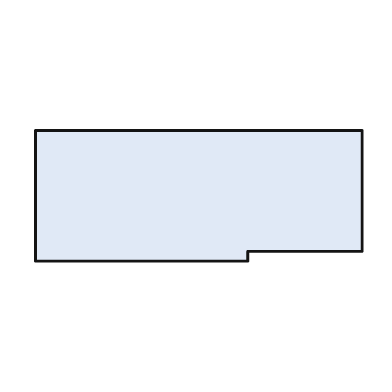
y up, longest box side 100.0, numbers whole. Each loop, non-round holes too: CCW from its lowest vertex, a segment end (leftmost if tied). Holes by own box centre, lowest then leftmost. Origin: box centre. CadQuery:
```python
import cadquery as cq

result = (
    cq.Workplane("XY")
    .moveTo(-50.0, -20.0)
    .lineTo(15.0, -20.0)
    .lineTo(15.0, -17.0)
    .lineTo(50.0, -17.0)
    .lineTo(50.0, 20.0)
    .lineTo(-50.0, 20.0)
    .close()
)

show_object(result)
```